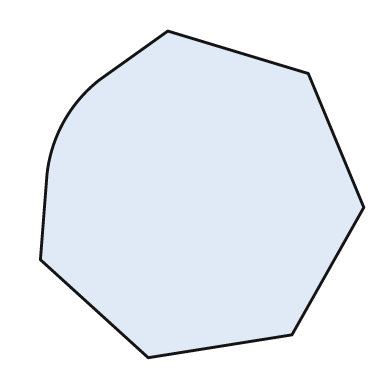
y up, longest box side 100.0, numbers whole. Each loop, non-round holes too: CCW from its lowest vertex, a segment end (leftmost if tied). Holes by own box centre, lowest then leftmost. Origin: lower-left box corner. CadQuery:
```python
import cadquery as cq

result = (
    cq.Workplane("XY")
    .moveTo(33.0, 0.0)
    .lineTo(77.0, 7.0)
    .lineTo(99.0, 46.0)
    .lineTo(82.0, 87.0)
    .lineTo(39.0, 100.0)
    .lineTo(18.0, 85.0)
    .threePointArc((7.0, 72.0), (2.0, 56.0))
    .lineTo(0.0, 30.0)
    .close()
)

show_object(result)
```